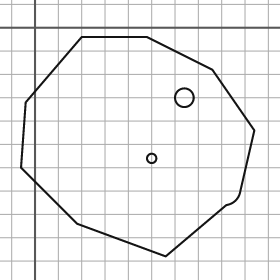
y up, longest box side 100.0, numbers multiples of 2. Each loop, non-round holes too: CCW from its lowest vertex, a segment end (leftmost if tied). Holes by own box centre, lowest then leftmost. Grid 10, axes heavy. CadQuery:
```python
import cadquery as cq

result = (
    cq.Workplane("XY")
    .moveTo(56.0, -98.0)
    .lineTo(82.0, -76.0)
    .threePointArc((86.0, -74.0), (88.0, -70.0))
    .lineTo(94.0, -44.0)
    .lineTo(76.0, -18.0)
    .lineTo(48.0, -4.0)
    .lineTo(20.0, -4.0)
    .lineTo(-4.0, -32.0)
    .lineTo(-6.0, -60.0)
    .lineTo(18.0, -84.0)
    .close()
    .moveTo(50.0, -56.0)
    .circle(2.0)
    .moveTo(64.0, -30.0)
    .circle(4.0)
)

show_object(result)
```